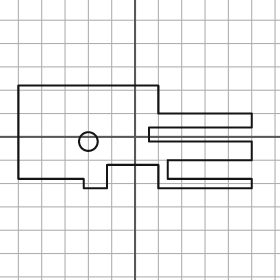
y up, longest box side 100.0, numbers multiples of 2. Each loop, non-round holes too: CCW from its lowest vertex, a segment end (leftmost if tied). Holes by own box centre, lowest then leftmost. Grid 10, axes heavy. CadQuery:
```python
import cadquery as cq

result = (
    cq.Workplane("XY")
    .moveTo(-22.0, -22.0)
    .lineTo(-12.0, -22.0)
    .lineTo(-12.0, -12.0)
    .lineTo(10.0, -12.0)
    .lineTo(10.0, -22.0)
    .lineTo(50.0, -22.0)
    .lineTo(50.0, -18.0)
    .lineTo(14.0, -18.0)
    .lineTo(14.0, -10.0)
    .lineTo(50.0, -10.0)
    .lineTo(50.0, -2.0)
    .lineTo(6.0, -2.0)
    .lineTo(6.0, 4.0)
    .lineTo(50.0, 4.0)
    .lineTo(50.0, 10.0)
    .lineTo(10.0, 10.0)
    .lineTo(10.0, 22.0)
    .lineTo(-50.0, 22.0)
    .lineTo(-50.0, -18.0)
    .lineTo(-22.0, -18.0)
    .close()
    .moveTo(-20.0, -2.0)
    .circle(4.0)
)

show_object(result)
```